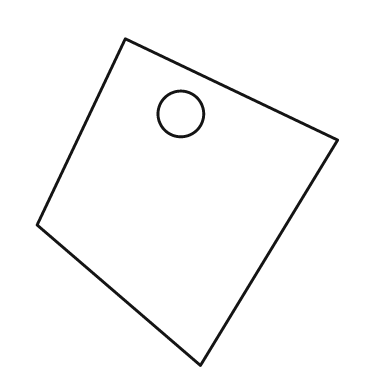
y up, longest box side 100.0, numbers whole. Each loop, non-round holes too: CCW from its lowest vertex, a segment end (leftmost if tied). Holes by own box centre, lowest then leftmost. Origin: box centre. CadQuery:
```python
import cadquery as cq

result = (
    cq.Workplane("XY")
    .moveTo(4.0, -50.0)
    .lineTo(46.0, 19.0)
    .lineTo(-19.0, 50.0)
    .lineTo(-46.0, -7.0)
    .close()
    .moveTo(-2.0, 27.0)
    .circle(7.0)
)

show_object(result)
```